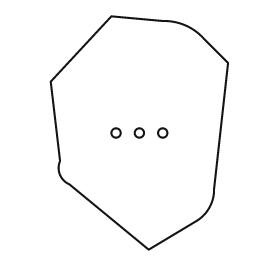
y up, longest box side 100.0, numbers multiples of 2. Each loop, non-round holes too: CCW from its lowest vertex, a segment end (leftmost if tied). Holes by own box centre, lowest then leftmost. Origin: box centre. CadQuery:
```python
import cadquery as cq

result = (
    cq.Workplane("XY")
    .moveTo(4.0, -50.0)
    .lineTo(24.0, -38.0)
    .threePointArc((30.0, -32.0), (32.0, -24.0))
    .lineTo(38.0, 30.0)
    .lineTo(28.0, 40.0)
    .threePointArc((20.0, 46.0), (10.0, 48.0))
    .lineTo(-12.0, 50.0)
    .lineTo(-38.0, 22.0)
    .lineTo(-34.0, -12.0)
    .threePointArc((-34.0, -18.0), (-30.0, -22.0))
    .close()
    .moveTo(-10.0, 0.0)
    .circle(2.0)
    .moveTo(0.0, 0.0)
    .circle(2.0)
    .moveTo(10.0, 0.0)
    .circle(2.0)
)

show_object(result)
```